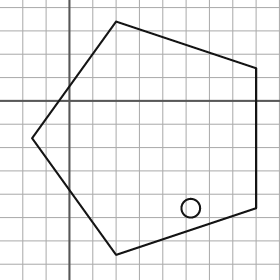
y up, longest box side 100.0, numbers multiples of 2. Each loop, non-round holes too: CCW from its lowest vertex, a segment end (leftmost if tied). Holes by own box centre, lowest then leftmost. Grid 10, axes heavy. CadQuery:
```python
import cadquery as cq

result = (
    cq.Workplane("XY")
    .moveTo(20.0, -66.0)
    .lineTo(80.0, -46.0)
    .lineTo(80.0, 14.0)
    .lineTo(20.0, 34.0)
    .lineTo(-16.0, -16.0)
    .close()
    .moveTo(52.0, -46.0)
    .circle(4.0)
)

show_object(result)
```